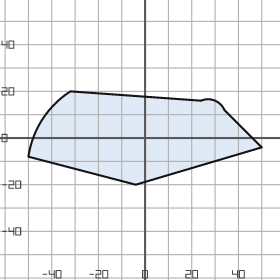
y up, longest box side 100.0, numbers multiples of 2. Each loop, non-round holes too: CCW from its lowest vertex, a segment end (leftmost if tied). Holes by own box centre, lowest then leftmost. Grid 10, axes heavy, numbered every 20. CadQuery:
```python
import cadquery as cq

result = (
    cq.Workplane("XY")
    .moveTo(-4.0, -20.0)
    .lineTo(50.0, -4.0)
    .lineTo(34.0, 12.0)
    .threePointArc((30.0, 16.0), (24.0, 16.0))
    .lineTo(-32.0, 20.0)
    .threePointArc((-44.0, 8.0), (-50.0, -8.0))
    .close()
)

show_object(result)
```